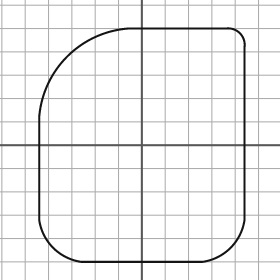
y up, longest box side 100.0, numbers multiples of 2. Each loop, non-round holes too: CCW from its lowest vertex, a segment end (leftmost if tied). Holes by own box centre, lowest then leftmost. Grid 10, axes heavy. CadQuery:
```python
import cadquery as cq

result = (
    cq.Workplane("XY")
    .moveTo(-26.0, -50.0)
    .lineTo(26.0, -50.0)
    .threePointArc((38.0, -44.0), (44.0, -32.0))
    .lineTo(44.0, 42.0)
    .threePointArc((42.0, 48.0), (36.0, 50.0))
    .lineTo(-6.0, 50.0)
    .threePointArc((-32.0, 38.0), (-44.0, 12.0))
    .lineTo(-44.0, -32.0)
    .threePointArc((-38.0, -44.0), (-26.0, -50.0))
    .close()
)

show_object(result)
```